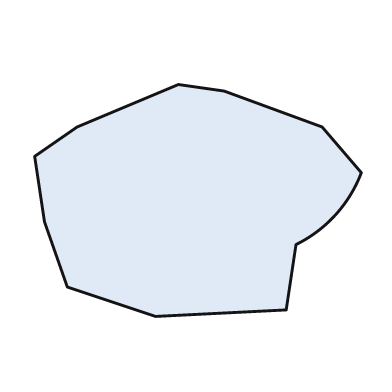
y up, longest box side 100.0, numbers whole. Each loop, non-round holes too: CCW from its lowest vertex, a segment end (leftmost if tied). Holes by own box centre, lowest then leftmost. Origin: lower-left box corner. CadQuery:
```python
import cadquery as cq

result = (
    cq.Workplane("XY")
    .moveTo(37.0, 0.0)
    .lineTo(77.0, 2.0)
    .lineTo(80.0, 22.0)
    .threePointArc((92.0, 31.0), (100.0, 44.0))
    .lineTo(88.0, 58.0)
    .lineTo(58.0, 69.0)
    .lineTo(44.0, 71.0)
    .lineTo(13.0, 58.0)
    .lineTo(0.0, 49.0)
    .lineTo(3.0, 29.0)
    .lineTo(10.0, 9.0)
    .close()
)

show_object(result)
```